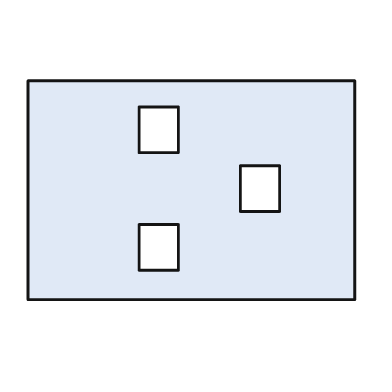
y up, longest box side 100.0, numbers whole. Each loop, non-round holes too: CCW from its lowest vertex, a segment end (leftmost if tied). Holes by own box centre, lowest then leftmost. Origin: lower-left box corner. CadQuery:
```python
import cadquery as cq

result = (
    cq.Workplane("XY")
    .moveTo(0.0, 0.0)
    .lineTo(100.0, 0.0)
    .lineTo(100.0, 67.0)
    .lineTo(0.0, 67.0)
    .close()
    .moveTo(34.0, 9.0)
    .lineTo(46.0, 9.0)
    .lineTo(46.0, 23.0)
    .lineTo(34.0, 23.0)
    .close()
    .moveTo(65.0, 27.0)
    .lineTo(77.0, 27.0)
    .lineTo(77.0, 41.0)
    .lineTo(65.0, 41.0)
    .close()
    .moveTo(34.0, 45.0)
    .lineTo(46.0, 45.0)
    .lineTo(46.0, 59.0)
    .lineTo(34.0, 59.0)
    .close()
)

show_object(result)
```